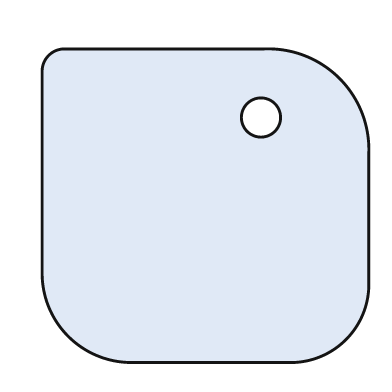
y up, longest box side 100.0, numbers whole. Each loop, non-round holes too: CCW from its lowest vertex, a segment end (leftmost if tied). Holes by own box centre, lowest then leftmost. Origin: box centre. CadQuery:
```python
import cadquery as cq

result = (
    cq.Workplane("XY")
    .moveTo(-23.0, -48.0)
    .lineTo(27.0, -48.0)
    .threePointArc((43.0, -41.0), (50.0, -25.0))
    .lineTo(50.0, 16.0)
    .threePointArc((41.0, 39.0), (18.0, 48.0))
    .lineTo(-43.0, 48.0)
    .threePointArc((-48.0, 46.0), (-50.0, 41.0))
    .lineTo(-50.0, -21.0)
    .threePointArc((-42.0, -40.0), (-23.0, -48.0))
    .close()
    .moveTo(17.0, 27.0)
    .circle(6.0)
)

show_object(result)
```